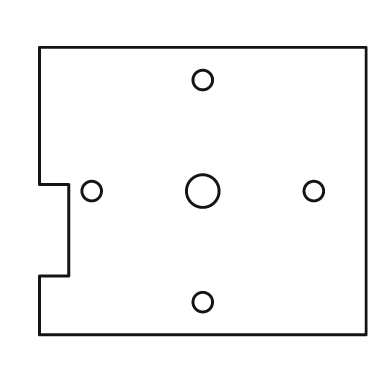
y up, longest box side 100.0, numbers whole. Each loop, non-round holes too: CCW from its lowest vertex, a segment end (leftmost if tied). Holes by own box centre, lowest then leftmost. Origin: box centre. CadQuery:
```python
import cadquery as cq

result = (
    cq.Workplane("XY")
    .moveTo(-50.0, -44.0)
    .lineTo(50.0, -44.0)
    .lineTo(50.0, 44.0)
    .lineTo(-50.0, 44.0)
    .lineTo(-50.0, 2.0)
    .lineTo(-41.0, 2.0)
    .lineTo(-41.0, -26.0)
    .lineTo(-50.0, -26.0)
    .close()
    .moveTo(0.0, -34.0)
    .circle(3.0)
    .moveTo(-34.0, 0.0)
    .circle(3.0)
    .moveTo(0.0, 0.0)
    .circle(5.0)
    .moveTo(34.0, 0.0)
    .circle(3.0)
    .moveTo(0.0, 34.0)
    .circle(3.0)
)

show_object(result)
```